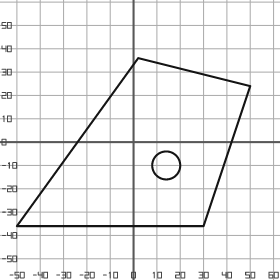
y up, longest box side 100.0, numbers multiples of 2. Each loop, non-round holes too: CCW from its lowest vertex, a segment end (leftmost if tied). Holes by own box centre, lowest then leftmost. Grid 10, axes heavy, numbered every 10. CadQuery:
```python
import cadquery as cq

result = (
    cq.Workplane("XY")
    .moveTo(-50.0, -36.0)
    .lineTo(30.0, -36.0)
    .lineTo(50.0, 24.0)
    .lineTo(2.0, 36.0)
    .close()
    .moveTo(14.0, -10.0)
    .circle(6.0)
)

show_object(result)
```